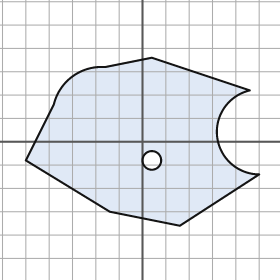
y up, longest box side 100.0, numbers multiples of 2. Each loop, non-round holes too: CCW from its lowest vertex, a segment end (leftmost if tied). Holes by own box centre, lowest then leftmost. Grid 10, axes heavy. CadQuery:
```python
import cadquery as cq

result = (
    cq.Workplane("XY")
    .moveTo(16.0, -36.0)
    .lineTo(50.0, -14.0)
    .threePointArc((32.0, 2.0), (46.0, 22.0))
    .lineTo(4.0, 36.0)
    .lineTo(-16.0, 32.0)
    .threePointArc((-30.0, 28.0), (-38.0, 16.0))
    .lineTo(-50.0, -8.0)
    .lineTo(-14.0, -30.0)
    .close()
    .moveTo(4.0, -8.0)
    .circle(4.0)
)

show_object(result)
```